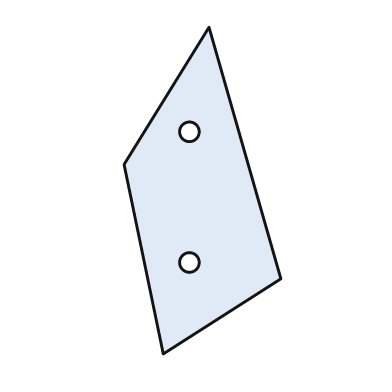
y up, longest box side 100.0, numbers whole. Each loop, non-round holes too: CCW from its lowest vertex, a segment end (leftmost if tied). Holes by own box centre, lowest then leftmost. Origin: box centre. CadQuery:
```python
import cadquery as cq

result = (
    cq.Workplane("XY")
    .moveTo(-12.0, -50.0)
    .lineTo(24.0, -27.0)
    .lineTo(2.0, 50.0)
    .lineTo(-24.0, 8.0)
    .close()
    .moveTo(-4.0, -22.0)
    .circle(3.0)
    .moveTo(-4.0, 18.0)
    .circle(3.0)
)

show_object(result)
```